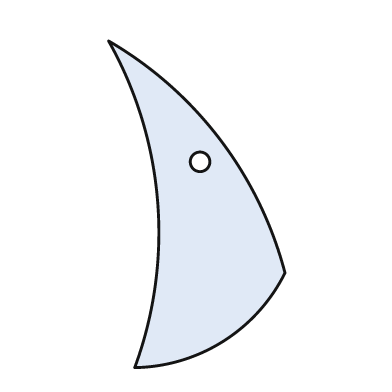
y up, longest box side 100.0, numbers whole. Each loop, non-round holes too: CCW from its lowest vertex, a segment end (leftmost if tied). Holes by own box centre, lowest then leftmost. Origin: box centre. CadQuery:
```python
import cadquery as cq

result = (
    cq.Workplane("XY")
    .moveTo(-19.0, -50.0)
    .threePointArc((8.0, -42.0), (27.0, -21.0))
    .threePointArc((7.0, 20.0), (-27.0, 50.0))
    .threePointArc((-12.0, 1.0), (-19.0, -50.0))
    .close()
    .moveTo(1.0, 13.0)
    .circle(3.0)
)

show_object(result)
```